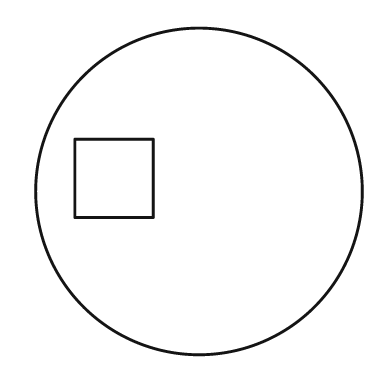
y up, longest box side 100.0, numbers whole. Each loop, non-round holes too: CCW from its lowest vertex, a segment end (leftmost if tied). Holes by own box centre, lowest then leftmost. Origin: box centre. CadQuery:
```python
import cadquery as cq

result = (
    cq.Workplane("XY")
    .moveTo(0.0, 0.0)
    .circle(50.0)
    .moveTo(-38.0, -8.0)
    .lineTo(-14.0, -8.0)
    .lineTo(-14.0, 16.0)
    .lineTo(-38.0, 16.0)
    .close()
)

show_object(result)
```